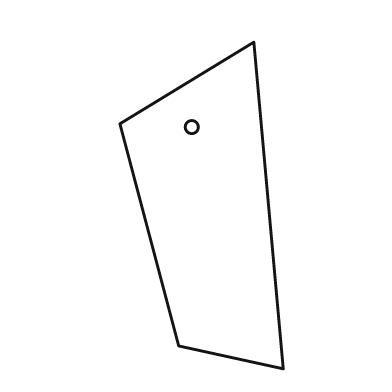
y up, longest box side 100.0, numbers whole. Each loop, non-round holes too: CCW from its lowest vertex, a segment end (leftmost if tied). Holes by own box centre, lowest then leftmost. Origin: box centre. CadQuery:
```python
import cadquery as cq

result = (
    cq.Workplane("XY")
    .moveTo(25.0, -50.0)
    .lineTo(16.0, 50.0)
    .lineTo(-25.0, 25.0)
    .lineTo(-7.0, -43.0)
    .close()
    .moveTo(-3.0, 24.0)
    .circle(2.0)
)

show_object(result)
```